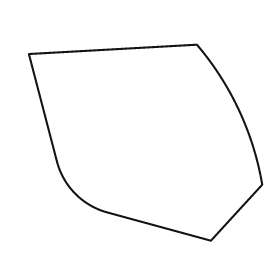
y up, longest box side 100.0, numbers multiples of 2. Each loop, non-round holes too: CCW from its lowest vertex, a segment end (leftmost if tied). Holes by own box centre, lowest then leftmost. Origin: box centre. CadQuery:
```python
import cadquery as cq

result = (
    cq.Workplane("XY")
    .moveTo(28.0, -42.0)
    .lineTo(50.0, -18.0)
    .threePointArc((40.0, 14.0), (22.0, 42.0))
    .lineTo(-50.0, 38.0)
    .lineTo(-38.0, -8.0)
    .threePointArc((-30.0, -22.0), (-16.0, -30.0))
    .close()
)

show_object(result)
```